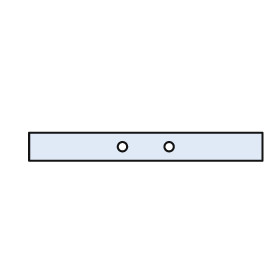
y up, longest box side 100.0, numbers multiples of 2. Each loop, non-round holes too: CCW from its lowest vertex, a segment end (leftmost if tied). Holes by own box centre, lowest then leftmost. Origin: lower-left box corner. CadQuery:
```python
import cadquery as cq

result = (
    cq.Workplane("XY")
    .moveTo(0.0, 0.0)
    .lineTo(100.0, 0.0)
    .lineTo(100.0, 12.0)
    .lineTo(0.0, 12.0)
    .close()
    .moveTo(40.0, 6.0)
    .circle(2.0)
    .moveTo(60.0, 6.0)
    .circle(2.0)
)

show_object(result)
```